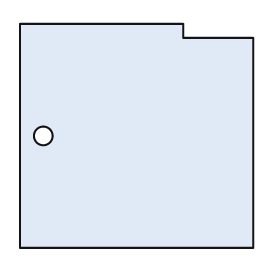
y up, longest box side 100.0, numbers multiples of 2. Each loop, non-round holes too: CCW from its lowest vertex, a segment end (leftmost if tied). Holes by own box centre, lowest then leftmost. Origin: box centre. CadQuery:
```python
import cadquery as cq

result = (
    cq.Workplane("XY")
    .moveTo(-50.0, -48.0)
    .lineTo(50.0, -48.0)
    .lineTo(50.0, 42.0)
    .lineTo(20.0, 42.0)
    .lineTo(20.0, 48.0)
    .lineTo(-50.0, 48.0)
    .close()
    .moveTo(-40.0, 0.0)
    .circle(4.0)
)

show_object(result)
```